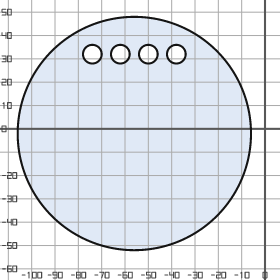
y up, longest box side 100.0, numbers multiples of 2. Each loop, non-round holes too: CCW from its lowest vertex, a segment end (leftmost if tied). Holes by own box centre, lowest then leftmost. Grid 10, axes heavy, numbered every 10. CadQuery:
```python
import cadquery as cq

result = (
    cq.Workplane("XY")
    .moveTo(-56.0, -2.0)
    .circle(50.0)
    .moveTo(-74.0, 32.0)
    .circle(4.0)
    .moveTo(-62.0, 32.0)
    .circle(4.0)
    .moveTo(-50.0, 32.0)
    .circle(4.0)
    .moveTo(-38.0, 32.0)
    .circle(4.0)
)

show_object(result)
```